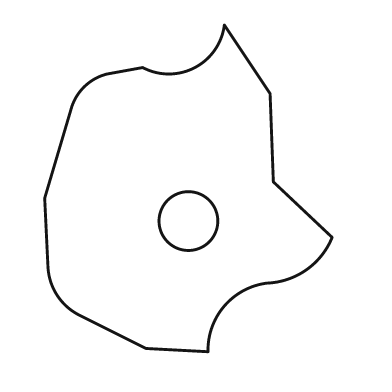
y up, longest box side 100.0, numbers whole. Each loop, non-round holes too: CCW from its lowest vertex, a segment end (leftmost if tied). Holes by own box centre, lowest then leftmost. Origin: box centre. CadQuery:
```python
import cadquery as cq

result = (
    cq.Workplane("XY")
    .moveTo(6.0, -50.0)
    .threePointArc((11.0, -36.0), (24.0, -29.0))
    .threePointArc((36.0, -25.0), (44.0, -15.0))
    .lineTo(26.0, 2.0)
    .lineTo(25.0, 29.0)
    .lineTo(11.0, 50.0)
    .threePointArc((2.0, 37.0), (-14.0, 37.0))
    .lineTo(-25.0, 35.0)
    .threePointArc((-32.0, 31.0), (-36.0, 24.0))
    .lineTo(-44.0, -3.0)
    .lineTo(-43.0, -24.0)
    .threePointArc((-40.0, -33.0), (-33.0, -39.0))
    .lineTo(-13.0, -49.0)
    .close()
    .moveTo(0.0, -10.0)
    .circle(9.0)
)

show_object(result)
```